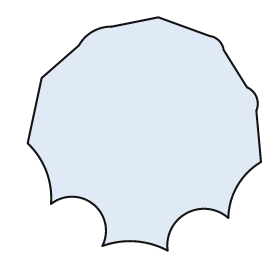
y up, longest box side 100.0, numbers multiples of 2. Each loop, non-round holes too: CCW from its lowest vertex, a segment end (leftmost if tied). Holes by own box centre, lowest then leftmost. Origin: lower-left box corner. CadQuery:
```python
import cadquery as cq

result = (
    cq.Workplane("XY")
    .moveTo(60.0, 0.0)
    .threePointArc((68.0, 16.0), (86.0, 14.0))
    .threePointArc((90.0, 28.0), (100.0, 38.0))
    .lineTo(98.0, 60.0)
    .threePointArc((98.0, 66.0), (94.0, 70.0))
    .lineTo(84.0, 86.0)
    .threePointArc((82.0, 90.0), (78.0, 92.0))
    .lineTo(56.0, 100.0)
    .lineTo(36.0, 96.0)
    .threePointArc((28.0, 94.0), (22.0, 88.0))
    .lineTo(6.0, 74.0)
    .lineTo(0.0, 46.0)
    .threePointArc((8.0, 34.0), (10.0, 20.0))
    .threePointArc((28.0, 20.0), (32.0, 2.0))
    .threePointArc((46.0, 4.0), (60.0, 0.0))
    .close()
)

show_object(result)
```